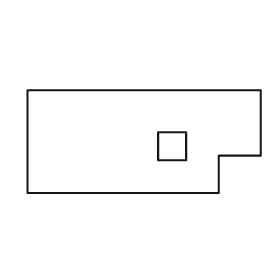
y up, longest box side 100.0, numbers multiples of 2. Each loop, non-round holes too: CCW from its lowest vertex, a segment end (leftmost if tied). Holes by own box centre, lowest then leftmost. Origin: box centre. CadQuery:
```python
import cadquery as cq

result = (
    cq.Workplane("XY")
    .moveTo(-50.0, -22.0)
    .lineTo(32.0, -22.0)
    .lineTo(32.0, -6.0)
    .lineTo(50.0, -6.0)
    .lineTo(50.0, 22.0)
    .lineTo(-50.0, 22.0)
    .close()
    .moveTo(6.0, -8.0)
    .lineTo(18.0, -8.0)
    .lineTo(18.0, 4.0)
    .lineTo(6.0, 4.0)
    .close()
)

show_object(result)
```